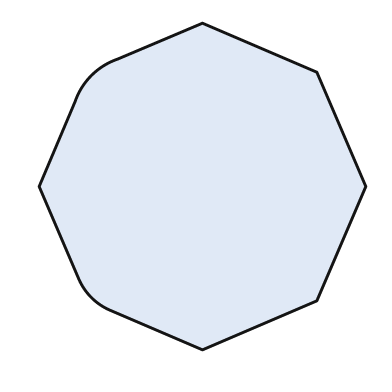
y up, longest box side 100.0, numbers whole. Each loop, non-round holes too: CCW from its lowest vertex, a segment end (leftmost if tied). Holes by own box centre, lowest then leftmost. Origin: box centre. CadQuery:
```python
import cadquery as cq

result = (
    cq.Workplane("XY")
    .moveTo(0.0, -50.0)
    .lineTo(35.0, -35.0)
    .lineTo(50.0, 0.0)
    .lineTo(35.0, 35.0)
    .lineTo(0.0, 50.0)
    .lineTo(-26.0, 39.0)
    .threePointArc((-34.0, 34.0), (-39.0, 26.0))
    .lineTo(-50.0, 0.0)
    .lineTo(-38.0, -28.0)
    .threePointArc((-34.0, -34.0), (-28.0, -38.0))
    .close()
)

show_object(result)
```